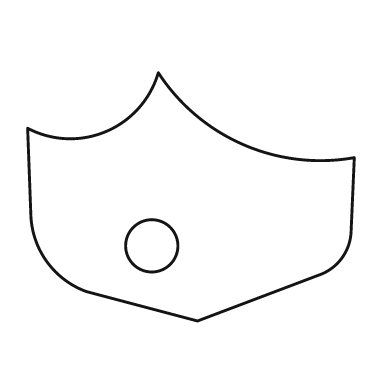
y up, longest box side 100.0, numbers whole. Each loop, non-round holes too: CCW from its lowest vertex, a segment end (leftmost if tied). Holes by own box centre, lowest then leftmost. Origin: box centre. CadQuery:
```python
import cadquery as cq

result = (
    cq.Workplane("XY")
    .moveTo(2.0, -38.0)
    .lineTo(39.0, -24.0)
    .threePointArc((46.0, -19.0), (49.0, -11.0))
    .lineTo(50.0, 12.0)
    .threePointArc((16.0, 16.0), (-10.0, 38.0))
    .threePointArc((-26.0, 20.0), (-50.0, 21.0))
    .lineTo(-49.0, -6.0)
    .threePointArc((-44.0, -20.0), (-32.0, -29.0))
    .close()
    .moveTo(-12.0, -15.0)
    .circle(8.0)
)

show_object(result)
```